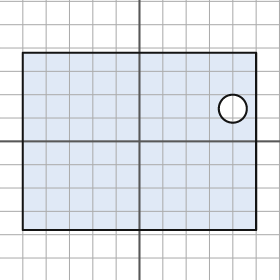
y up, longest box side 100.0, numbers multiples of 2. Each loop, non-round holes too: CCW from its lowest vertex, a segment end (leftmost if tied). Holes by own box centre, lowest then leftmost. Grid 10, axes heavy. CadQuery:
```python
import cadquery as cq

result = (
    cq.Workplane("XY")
    .moveTo(-50.0, -38.0)
    .lineTo(50.0, -38.0)
    .lineTo(50.0, 38.0)
    .lineTo(-50.0, 38.0)
    .close()
    .moveTo(40.0, 14.0)
    .circle(6.0)
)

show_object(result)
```